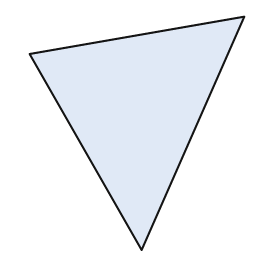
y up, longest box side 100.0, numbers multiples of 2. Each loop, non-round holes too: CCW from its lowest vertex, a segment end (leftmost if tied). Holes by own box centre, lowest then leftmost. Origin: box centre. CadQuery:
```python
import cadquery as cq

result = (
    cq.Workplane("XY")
    .moveTo(2.0, -50.0)
    .lineTo(46.0, 50.0)
    .lineTo(-46.0, 34.0)
    .close()
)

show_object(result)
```